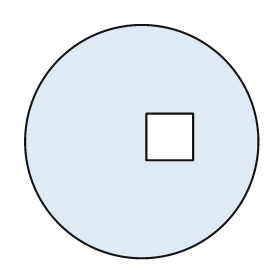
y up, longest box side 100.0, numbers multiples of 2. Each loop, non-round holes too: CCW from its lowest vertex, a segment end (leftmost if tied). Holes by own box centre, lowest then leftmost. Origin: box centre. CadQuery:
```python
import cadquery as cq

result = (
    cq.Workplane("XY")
    .moveTo(0.0, 0.0)
    .circle(50.0)
    .moveTo(2.0, -8.0)
    .lineTo(22.0, -8.0)
    .lineTo(22.0, 12.0)
    .lineTo(2.0, 12.0)
    .close()
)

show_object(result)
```